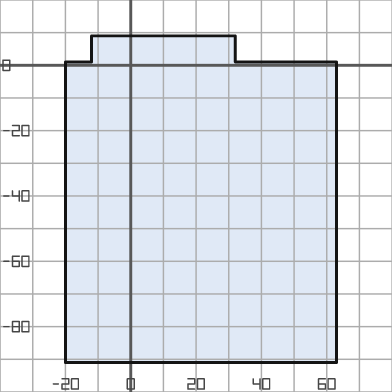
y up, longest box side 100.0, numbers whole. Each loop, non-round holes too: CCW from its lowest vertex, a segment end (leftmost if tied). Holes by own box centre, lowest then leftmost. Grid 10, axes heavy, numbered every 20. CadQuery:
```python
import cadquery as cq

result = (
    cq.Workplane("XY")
    .moveTo(-20.0, -91.0)
    .lineTo(63.0, -91.0)
    .lineTo(63.0, 1.0)
    .lineTo(32.0, 1.0)
    .lineTo(32.0, 9.0)
    .lineTo(-12.0, 9.0)
    .lineTo(-12.0, 1.0)
    .lineTo(-20.0, 1.0)
    .close()
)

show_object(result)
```